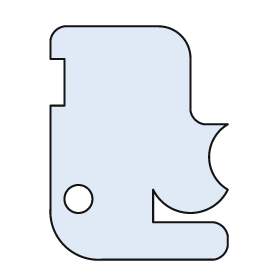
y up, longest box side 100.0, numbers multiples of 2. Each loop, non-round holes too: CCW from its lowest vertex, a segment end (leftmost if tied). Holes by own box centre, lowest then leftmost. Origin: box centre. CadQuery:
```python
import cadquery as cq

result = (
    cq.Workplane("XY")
    .moveTo(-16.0, -50.0)
    .lineTo(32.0, -50.0)
    .threePointArc((36.0, -48.0), (38.0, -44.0))
    .lineTo(38.0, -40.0)
    .threePointArc((36.0, -36.0), (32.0, -34.0))
    .lineTo(6.0, -34.0)
    .lineTo(6.0, -20.0)
    .threePointArc((22.0, -30.0), (38.0, -20.0))
    .threePointArc((30.0, -6.0), (38.0, 8.0))
    .lineTo(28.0, 8.0)
    .threePointArc((24.0, 10.0), (22.0, 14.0))
    .lineTo(22.0, 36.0)
    .threePointArc((18.0, 46.0), (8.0, 50.0))
    .lineTo(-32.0, 50.0)
    .threePointArc((-36.0, 48.0), (-38.0, 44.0))
    .lineTo(-38.0, 36.0)
    .lineTo(-32.0, 36.0)
    .lineTo(-32.0, 16.0)
    .lineTo(-38.0, 16.0)
    .lineTo(-38.0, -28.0)
    .threePointArc((-32.0, -44.0), (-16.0, -50.0))
    .close()
    .moveTo(-26.0, -24.0)
    .circle(6.0)
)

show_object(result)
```